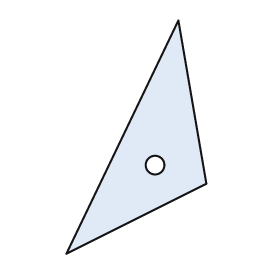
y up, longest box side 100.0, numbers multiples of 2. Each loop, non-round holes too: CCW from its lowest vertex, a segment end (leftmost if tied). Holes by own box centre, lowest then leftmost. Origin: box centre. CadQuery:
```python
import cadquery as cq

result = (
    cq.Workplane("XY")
    .moveTo(-30.0, -50.0)
    .lineTo(30.0, -20.0)
    .lineTo(18.0, 50.0)
    .close()
    .moveTo(8.0, -12.0)
    .circle(4.0)
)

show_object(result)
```